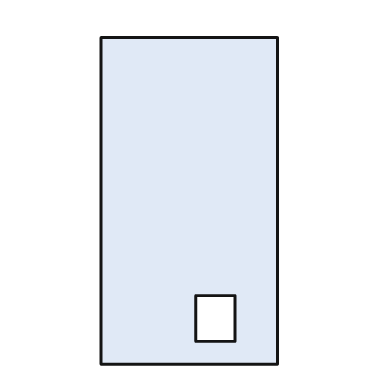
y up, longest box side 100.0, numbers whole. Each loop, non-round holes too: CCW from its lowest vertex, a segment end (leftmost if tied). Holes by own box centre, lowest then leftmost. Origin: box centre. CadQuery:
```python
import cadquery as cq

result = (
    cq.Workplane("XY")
    .moveTo(-27.0, -50.0)
    .lineTo(27.0, -50.0)
    .lineTo(27.0, 50.0)
    .lineTo(-27.0, 50.0)
    .close()
    .moveTo(2.0, -43.0)
    .lineTo(14.0, -43.0)
    .lineTo(14.0, -29.0)
    .lineTo(2.0, -29.0)
    .close()
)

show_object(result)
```